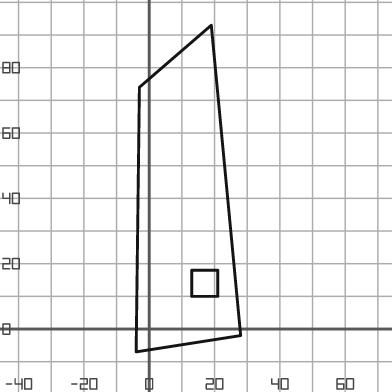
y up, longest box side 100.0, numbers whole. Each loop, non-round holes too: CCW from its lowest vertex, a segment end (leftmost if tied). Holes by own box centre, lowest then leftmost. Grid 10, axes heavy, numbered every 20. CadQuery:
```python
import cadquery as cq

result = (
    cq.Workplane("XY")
    .moveTo(-4.0, -7.0)
    .lineTo(28.0, -2.0)
    .lineTo(19.0, 93.0)
    .lineTo(-3.0, 74.0)
    .close()
    .moveTo(13.0, 10.0)
    .lineTo(21.0, 10.0)
    .lineTo(21.0, 18.0)
    .lineTo(13.0, 18.0)
    .close()
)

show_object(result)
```